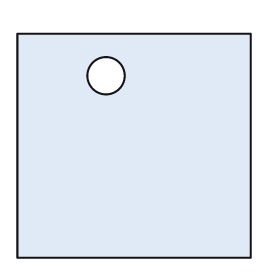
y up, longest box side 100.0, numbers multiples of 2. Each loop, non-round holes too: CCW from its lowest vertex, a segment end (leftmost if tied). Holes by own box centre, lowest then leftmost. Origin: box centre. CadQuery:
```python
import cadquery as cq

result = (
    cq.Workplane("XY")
    .moveTo(-50.0, -48.0)
    .lineTo(50.0, -48.0)
    .lineTo(50.0, 48.0)
    .lineTo(-50.0, 48.0)
    .close()
    .moveTo(-12.0, 30.0)
    .circle(8.0)
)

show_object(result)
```